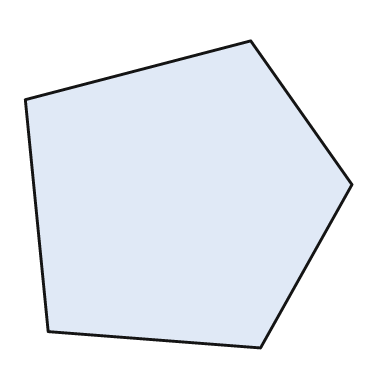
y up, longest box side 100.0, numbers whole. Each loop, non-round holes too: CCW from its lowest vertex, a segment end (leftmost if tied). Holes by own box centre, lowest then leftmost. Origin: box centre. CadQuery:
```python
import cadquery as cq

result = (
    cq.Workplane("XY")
    .moveTo(22.0, -47.0)
    .lineTo(50.0, 3.0)
    .lineTo(19.0, 47.0)
    .lineTo(-50.0, 29.0)
    .lineTo(-43.0, -42.0)
    .close()
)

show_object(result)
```